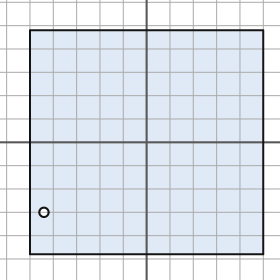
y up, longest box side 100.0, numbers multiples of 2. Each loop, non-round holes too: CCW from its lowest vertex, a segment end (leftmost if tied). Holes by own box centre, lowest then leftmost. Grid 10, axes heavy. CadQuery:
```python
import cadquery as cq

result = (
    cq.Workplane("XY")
    .moveTo(-50.0, -48.0)
    .lineTo(50.0, -48.0)
    .lineTo(50.0, 48.0)
    .lineTo(-50.0, 48.0)
    .close()
    .moveTo(-44.0, -30.0)
    .circle(2.0)
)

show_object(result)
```